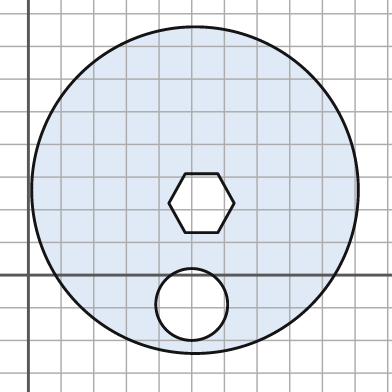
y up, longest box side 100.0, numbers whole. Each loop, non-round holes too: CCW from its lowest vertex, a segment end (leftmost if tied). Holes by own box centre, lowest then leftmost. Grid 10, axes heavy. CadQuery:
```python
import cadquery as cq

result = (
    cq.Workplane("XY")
    .moveTo(51.0, 26.0)
    .circle(50.0)
    .moveTo(50.0, -9.0)
    .circle(11.0)
    .moveTo(48.0, 13.0)
    .lineTo(58.0, 13.0)
    .lineTo(63.0, 22.0)
    .lineTo(58.0, 31.0)
    .lineTo(48.0, 31.0)
    .lineTo(43.0, 22.0)
    .close()
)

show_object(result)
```